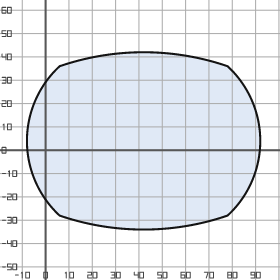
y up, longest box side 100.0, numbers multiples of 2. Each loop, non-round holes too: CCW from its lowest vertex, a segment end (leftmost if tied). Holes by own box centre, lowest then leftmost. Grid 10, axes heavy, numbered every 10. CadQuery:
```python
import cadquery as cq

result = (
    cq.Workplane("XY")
    .moveTo(6.0, -28.0)
    .threePointArc((42.0, -34.0), (78.0, -28.0))
    .threePointArc((92.0, 4.0), (78.0, 36.0))
    .threePointArc((42.0, 42.0), (6.0, 36.0))
    .threePointArc((-8.0, 4.0), (6.0, -28.0))
    .close()
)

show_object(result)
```